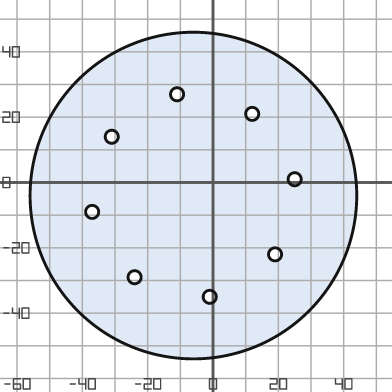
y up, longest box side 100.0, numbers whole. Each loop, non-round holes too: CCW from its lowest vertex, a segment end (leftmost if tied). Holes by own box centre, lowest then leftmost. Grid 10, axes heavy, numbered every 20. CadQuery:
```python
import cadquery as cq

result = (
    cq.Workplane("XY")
    .moveTo(-6.0, -4.0)
    .circle(50.0)
    .moveTo(-1.0, -35.0)
    .circle(2.0)
    .moveTo(-24.0, -29.0)
    .circle(2.0)
    .moveTo(19.0, -22.0)
    .circle(2.0)
    .moveTo(-37.0, -9.0)
    .circle(2.0)
    .moveTo(25.0, 1.0)
    .circle(2.0)
    .moveTo(-31.0, 14.0)
    .circle(2.0)
    .moveTo(12.0, 21.0)
    .circle(2.0)
    .moveTo(-11.0, 27.0)
    .circle(2.0)
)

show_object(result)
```